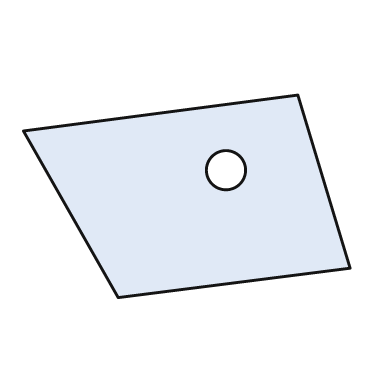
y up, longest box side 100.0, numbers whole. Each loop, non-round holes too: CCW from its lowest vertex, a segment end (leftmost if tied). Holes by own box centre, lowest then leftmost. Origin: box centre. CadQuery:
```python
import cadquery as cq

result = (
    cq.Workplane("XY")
    .moveTo(-21.0, -31.0)
    .lineTo(50.0, -22.0)
    .lineTo(34.0, 31.0)
    .lineTo(-50.0, 20.0)
    .close()
    .moveTo(12.0, 8.0)
    .circle(6.0)
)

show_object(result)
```